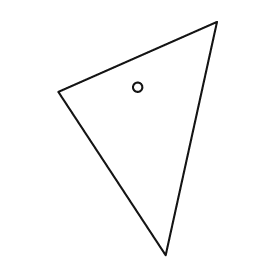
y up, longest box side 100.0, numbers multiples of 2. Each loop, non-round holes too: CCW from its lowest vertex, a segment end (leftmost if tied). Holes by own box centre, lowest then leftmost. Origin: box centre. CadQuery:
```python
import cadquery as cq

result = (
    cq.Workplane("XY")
    .moveTo(12.0, -50.0)
    .lineTo(34.0, 50.0)
    .lineTo(-34.0, 20.0)
    .close()
    .moveTo(0.0, 22.0)
    .circle(2.0)
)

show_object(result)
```